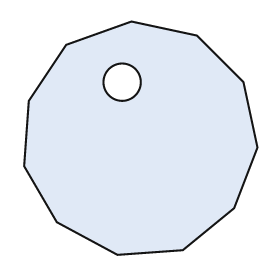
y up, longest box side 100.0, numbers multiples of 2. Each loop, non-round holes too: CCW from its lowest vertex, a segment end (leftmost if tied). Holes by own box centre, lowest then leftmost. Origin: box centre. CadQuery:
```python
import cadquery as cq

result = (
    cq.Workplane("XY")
    .moveTo(-10.0, -50.0)
    .lineTo(18.0, -48.0)
    .lineTo(40.0, -30.0)
    .lineTo(50.0, -4.0)
    .lineTo(44.0, 24.0)
    .lineTo(24.0, 44.0)
    .lineTo(-4.0, 50.0)
    .lineTo(-32.0, 40.0)
    .lineTo(-48.0, 16.0)
    .lineTo(-50.0, -12.0)
    .lineTo(-36.0, -36.0)
    .close()
    .moveTo(-8.0, 24.0)
    .circle(8.0)
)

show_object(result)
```